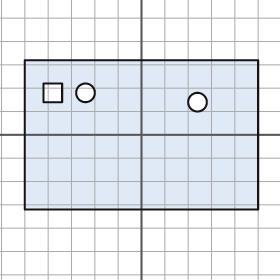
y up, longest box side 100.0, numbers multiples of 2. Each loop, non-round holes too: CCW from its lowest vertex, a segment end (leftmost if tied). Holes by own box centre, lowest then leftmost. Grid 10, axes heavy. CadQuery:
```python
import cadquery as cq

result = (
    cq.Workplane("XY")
    .moveTo(-50.0, -32.0)
    .lineTo(50.0, -32.0)
    .lineTo(50.0, 32.0)
    .lineTo(-50.0, 32.0)
    .close()
    .moveTo(24.0, 14.0)
    .circle(4.0)
    .moveTo(-42.0, 14.0)
    .lineTo(-34.0, 14.0)
    .lineTo(-34.0, 22.0)
    .lineTo(-42.0, 22.0)
    .close()
    .moveTo(-24.0, 18.0)
    .circle(4.0)
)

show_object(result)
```